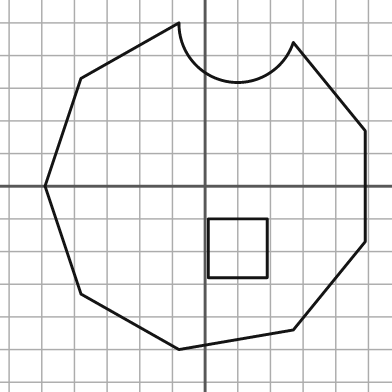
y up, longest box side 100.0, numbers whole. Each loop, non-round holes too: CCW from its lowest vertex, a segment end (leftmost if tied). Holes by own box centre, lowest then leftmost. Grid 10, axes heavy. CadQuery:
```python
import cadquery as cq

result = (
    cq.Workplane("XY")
    .moveTo(-8.0, -50.0)
    .lineTo(27.0, -44.0)
    .lineTo(49.0, -17.0)
    .lineTo(49.0, 17.0)
    .lineTo(27.0, 44.0)
    .threePointArc((7.0, 32.0), (-8.0, 50.0))
    .lineTo(-38.0, 33.0)
    .lineTo(-49.0, 0.0)
    .lineTo(-38.0, -33.0)
    .close()
    .moveTo(1.0, -28.0)
    .lineTo(19.0, -28.0)
    .lineTo(19.0, -10.0)
    .lineTo(1.0, -10.0)
    .close()
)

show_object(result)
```